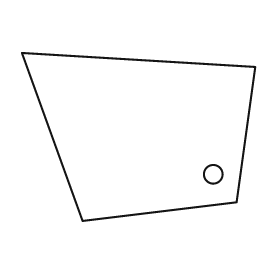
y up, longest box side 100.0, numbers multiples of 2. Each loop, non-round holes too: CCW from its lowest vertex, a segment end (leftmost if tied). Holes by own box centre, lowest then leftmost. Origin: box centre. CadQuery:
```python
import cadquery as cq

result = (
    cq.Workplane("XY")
    .moveTo(-24.0, -36.0)
    .lineTo(42.0, -28.0)
    .lineTo(50.0, 30.0)
    .lineTo(-50.0, 36.0)
    .close()
    .moveTo(32.0, -16.0)
    .circle(4.0)
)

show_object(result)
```